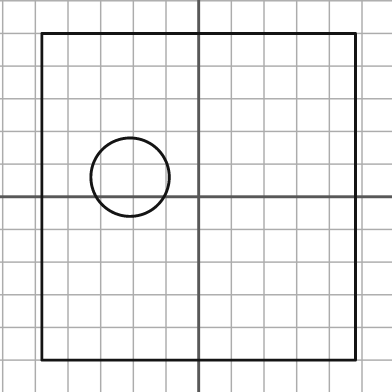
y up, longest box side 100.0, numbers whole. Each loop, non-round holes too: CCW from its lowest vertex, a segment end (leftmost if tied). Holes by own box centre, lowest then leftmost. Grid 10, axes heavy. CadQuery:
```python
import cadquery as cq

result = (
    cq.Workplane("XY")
    .moveTo(-48.0, -50.0)
    .lineTo(48.0, -50.0)
    .lineTo(48.0, 50.0)
    .lineTo(-48.0, 50.0)
    .close()
    .moveTo(-21.0, 6.0)
    .circle(12.0)
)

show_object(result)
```